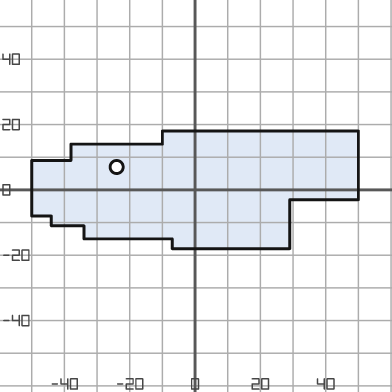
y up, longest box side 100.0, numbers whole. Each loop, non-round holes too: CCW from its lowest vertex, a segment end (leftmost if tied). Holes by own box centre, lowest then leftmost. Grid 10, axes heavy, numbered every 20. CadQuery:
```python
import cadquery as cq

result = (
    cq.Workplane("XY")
    .moveTo(-7.0, -18.0)
    .lineTo(29.0, -18.0)
    .lineTo(29.0, -3.0)
    .lineTo(50.0, -3.0)
    .lineTo(50.0, 18.0)
    .lineTo(-10.0, 18.0)
    .lineTo(-10.0, 14.0)
    .lineTo(-38.0, 14.0)
    .lineTo(-38.0, 9.0)
    .lineTo(-50.0, 9.0)
    .lineTo(-50.0, -8.0)
    .lineTo(-44.0, -8.0)
    .lineTo(-44.0, -11.0)
    .lineTo(-34.0, -11.0)
    .lineTo(-34.0, -15.0)
    .lineTo(-7.0, -15.0)
    .close()
    .moveTo(-24.0, 7.0)
    .circle(2.0)
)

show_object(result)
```